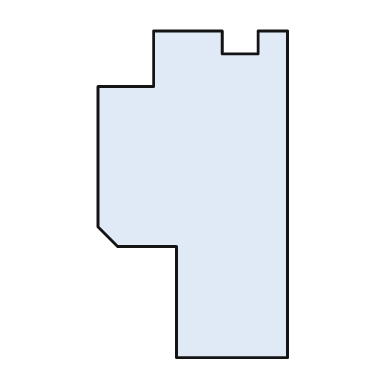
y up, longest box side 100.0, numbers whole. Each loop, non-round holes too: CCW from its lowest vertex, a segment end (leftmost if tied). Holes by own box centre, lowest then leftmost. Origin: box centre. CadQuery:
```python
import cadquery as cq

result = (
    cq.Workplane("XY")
    .moveTo(-5.0, -50.0)
    .lineTo(29.0, -50.0)
    .lineTo(29.0, 50.0)
    .lineTo(20.0, 50.0)
    .lineTo(20.0, 43.0)
    .lineTo(9.0, 43.0)
    .lineTo(9.0, 50.0)
    .lineTo(-12.0, 50.0)
    .lineTo(-12.0, 33.0)
    .lineTo(-29.0, 33.0)
    .lineTo(-29.0, -10.0)
    .lineTo(-23.0, -16.0)
    .lineTo(-5.0, -16.0)
    .close()
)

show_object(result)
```